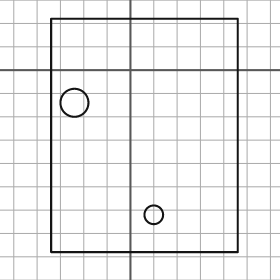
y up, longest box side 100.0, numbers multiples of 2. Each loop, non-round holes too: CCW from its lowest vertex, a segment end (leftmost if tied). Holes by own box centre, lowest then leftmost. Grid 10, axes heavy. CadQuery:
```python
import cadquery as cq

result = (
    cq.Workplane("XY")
    .moveTo(-34.0, -78.0)
    .lineTo(46.0, -78.0)
    .lineTo(46.0, 22.0)
    .lineTo(-34.0, 22.0)
    .close()
    .moveTo(10.0, -62.0)
    .circle(4.0)
    .moveTo(-24.0, -14.0)
    .circle(6.0)
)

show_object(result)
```